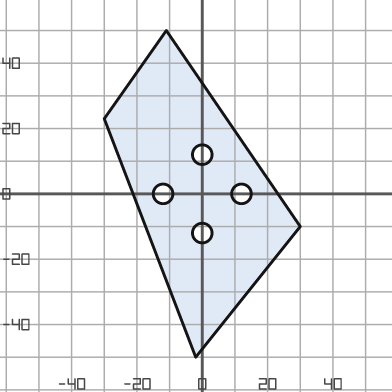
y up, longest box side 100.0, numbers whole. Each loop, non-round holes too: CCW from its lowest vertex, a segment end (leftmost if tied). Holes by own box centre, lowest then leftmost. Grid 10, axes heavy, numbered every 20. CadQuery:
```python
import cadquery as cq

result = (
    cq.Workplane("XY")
    .moveTo(-2.0, -50.0)
    .lineTo(30.0, -10.0)
    .lineTo(-11.0, 50.0)
    .lineTo(-30.0, 23.0)
    .close()
    .moveTo(0.0, -12.0)
    .circle(3.0)
    .moveTo(-12.0, 0.0)
    .circle(3.0)
    .moveTo(12.0, 0.0)
    .circle(3.0)
    .moveTo(0.0, 12.0)
    .circle(3.0)
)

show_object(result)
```